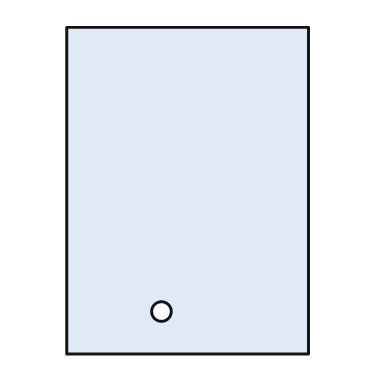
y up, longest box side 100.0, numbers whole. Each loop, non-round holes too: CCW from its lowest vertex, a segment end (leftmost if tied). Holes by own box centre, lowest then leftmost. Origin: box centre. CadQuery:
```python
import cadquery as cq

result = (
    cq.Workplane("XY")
    .moveTo(-37.0, -50.0)
    .lineTo(37.0, -50.0)
    .lineTo(37.0, 50.0)
    .lineTo(-37.0, 50.0)
    .close()
    .moveTo(-8.0, -37.0)
    .circle(3.0)
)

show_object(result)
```